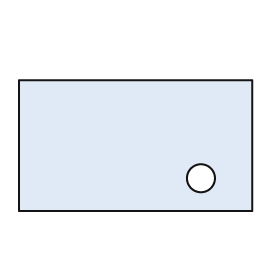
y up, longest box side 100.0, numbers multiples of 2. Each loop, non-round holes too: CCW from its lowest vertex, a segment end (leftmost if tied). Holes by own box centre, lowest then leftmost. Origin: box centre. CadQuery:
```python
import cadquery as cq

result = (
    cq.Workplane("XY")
    .moveTo(-50.0, -28.0)
    .lineTo(50.0, -28.0)
    .lineTo(50.0, 28.0)
    .lineTo(-50.0, 28.0)
    .close()
    .moveTo(28.0, -14.0)
    .circle(6.0)
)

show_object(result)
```